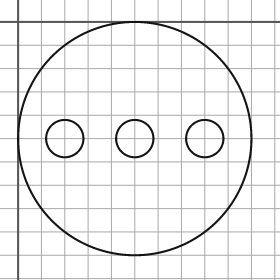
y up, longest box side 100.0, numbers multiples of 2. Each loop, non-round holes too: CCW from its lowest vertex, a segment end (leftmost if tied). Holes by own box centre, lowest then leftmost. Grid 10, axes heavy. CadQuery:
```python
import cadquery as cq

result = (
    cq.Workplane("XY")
    .moveTo(50.0, -50.0)
    .circle(50.0)
    .moveTo(20.0, -50.0)
    .circle(8.0)
    .moveTo(50.0, -50.0)
    .circle(8.0)
    .moveTo(80.0, -50.0)
    .circle(8.0)
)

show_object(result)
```